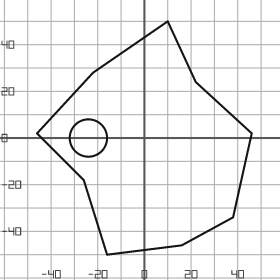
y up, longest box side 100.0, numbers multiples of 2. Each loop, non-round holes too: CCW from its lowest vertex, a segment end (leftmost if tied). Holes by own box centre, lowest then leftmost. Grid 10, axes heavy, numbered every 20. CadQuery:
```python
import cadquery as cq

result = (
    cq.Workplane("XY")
    .moveTo(-16.0, -50.0)
    .lineTo(16.0, -46.0)
    .lineTo(38.0, -34.0)
    .lineTo(46.0, 2.0)
    .lineTo(22.0, 24.0)
    .lineTo(10.0, 50.0)
    .lineTo(-22.0, 28.0)
    .lineTo(-46.0, 2.0)
    .lineTo(-26.0, -18.0)
    .close()
    .moveTo(-24.0, 0.0)
    .circle(8.0)
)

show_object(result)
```